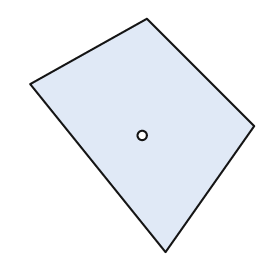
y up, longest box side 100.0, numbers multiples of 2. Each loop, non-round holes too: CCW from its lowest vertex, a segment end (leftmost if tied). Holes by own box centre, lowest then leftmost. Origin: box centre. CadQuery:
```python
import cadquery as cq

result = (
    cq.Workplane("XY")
    .moveTo(10.0, -50.0)
    .lineTo(48.0, 4.0)
    .lineTo(2.0, 50.0)
    .lineTo(-48.0, 22.0)
    .close()
    .moveTo(0.0, 0.0)
    .circle(2.0)
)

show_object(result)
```